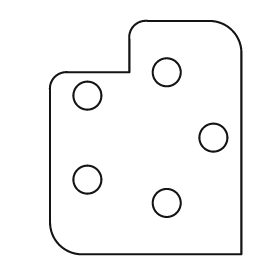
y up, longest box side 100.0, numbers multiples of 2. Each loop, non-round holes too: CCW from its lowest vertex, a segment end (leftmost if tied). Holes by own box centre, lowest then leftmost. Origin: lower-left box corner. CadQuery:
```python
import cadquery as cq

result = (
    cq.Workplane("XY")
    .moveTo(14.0, 0.0)
    .lineTo(82.0, 0.0)
    .lineTo(82.0, 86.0)
    .threePointArc((78.0, 96.0), (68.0, 100.0))
    .lineTo(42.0, 100.0)
    .threePointArc((36.0, 98.0), (34.0, 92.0))
    .lineTo(34.0, 78.0)
    .lineTo(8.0, 78.0)
    .threePointArc((2.0, 76.0), (0.0, 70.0))
    .lineTo(0.0, 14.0)
    .threePointArc((4.0, 4.0), (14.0, 0.0))
    .close()
    .moveTo(50.0, 22.0)
    .circle(6.0)
    .moveTo(16.0, 32.0)
    .circle(6.0)
    .moveTo(70.0, 50.0)
    .circle(6.0)
    .moveTo(16.0, 68.0)
    .circle(6.0)
    .moveTo(50.0, 78.0)
    .circle(6.0)
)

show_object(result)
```